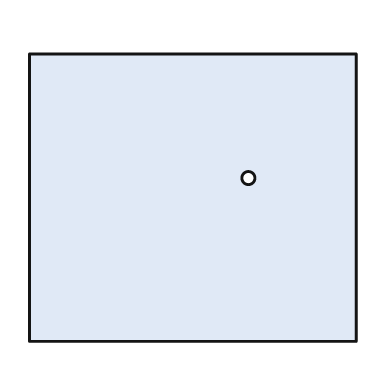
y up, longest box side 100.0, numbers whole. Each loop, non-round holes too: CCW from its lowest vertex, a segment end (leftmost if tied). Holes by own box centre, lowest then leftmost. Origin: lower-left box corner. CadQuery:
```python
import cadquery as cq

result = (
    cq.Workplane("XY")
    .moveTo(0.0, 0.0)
    .lineTo(100.0, 0.0)
    .lineTo(100.0, 88.0)
    .lineTo(0.0, 88.0)
    .close()
    .moveTo(67.0, 50.0)
    .circle(2.0)
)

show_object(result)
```